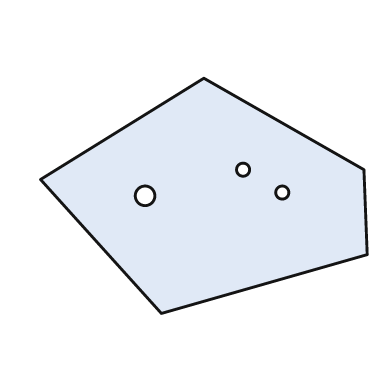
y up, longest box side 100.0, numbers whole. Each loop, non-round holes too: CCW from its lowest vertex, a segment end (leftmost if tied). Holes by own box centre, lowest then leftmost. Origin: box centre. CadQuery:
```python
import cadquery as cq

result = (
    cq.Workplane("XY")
    .moveTo(-13.0, -36.0)
    .lineTo(50.0, -18.0)
    .lineTo(49.0, 8.0)
    .lineTo(0.0, 36.0)
    .lineTo(-50.0, 5.0)
    .close()
    .moveTo(-18.0, 0.0)
    .circle(3.0)
    .moveTo(24.0, 1.0)
    .circle(2.0)
    .moveTo(12.0, 8.0)
    .circle(2.0)
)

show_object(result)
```